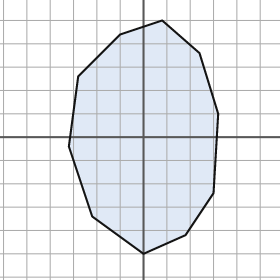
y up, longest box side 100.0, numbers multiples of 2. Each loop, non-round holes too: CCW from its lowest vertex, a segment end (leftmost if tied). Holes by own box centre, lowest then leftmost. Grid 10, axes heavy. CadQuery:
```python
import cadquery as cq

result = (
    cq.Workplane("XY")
    .moveTo(0.0, -50.0)
    .lineTo(18.0, -42.0)
    .lineTo(30.0, -24.0)
    .lineTo(32.0, 10.0)
    .lineTo(24.0, 36.0)
    .lineTo(8.0, 50.0)
    .lineTo(-10.0, 44.0)
    .lineTo(-28.0, 26.0)
    .lineTo(-32.0, -4.0)
    .lineTo(-22.0, -34.0)
    .close()
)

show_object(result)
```